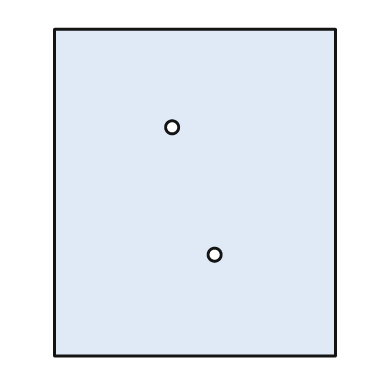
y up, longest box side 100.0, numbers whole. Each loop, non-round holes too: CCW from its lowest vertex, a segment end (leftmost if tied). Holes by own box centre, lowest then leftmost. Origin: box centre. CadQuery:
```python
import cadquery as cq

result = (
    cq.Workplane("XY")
    .moveTo(-43.0, -50.0)
    .lineTo(43.0, -50.0)
    .lineTo(43.0, 50.0)
    .lineTo(-43.0, 50.0)
    .close()
    .moveTo(6.0, -19.0)
    .circle(2.0)
    .moveTo(-7.0, 20.0)
    .circle(2.0)
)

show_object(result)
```